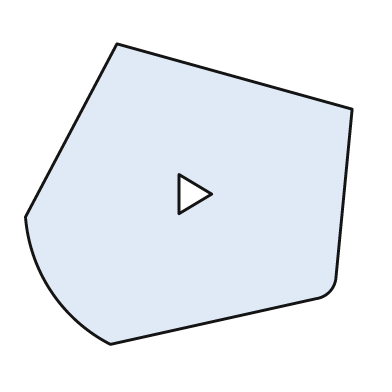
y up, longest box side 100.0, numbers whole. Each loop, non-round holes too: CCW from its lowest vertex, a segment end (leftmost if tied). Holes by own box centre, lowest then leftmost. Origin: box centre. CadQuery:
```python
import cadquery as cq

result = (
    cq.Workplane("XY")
    .moveTo(-24.0, -46.0)
    .lineTo(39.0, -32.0)
    .threePointArc((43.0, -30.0), (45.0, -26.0))
    .lineTo(50.0, 26.0)
    .lineTo(-22.0, 46.0)
    .lineTo(-50.0, -7.0)
    .threePointArc((-42.0, -30.0), (-24.0, -46.0))
    .close()
    .moveTo(-3.0, -6.0)
    .lineTo(7.0, 0.0)
    .lineTo(-3.0, 6.0)
    .close()
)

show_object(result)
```